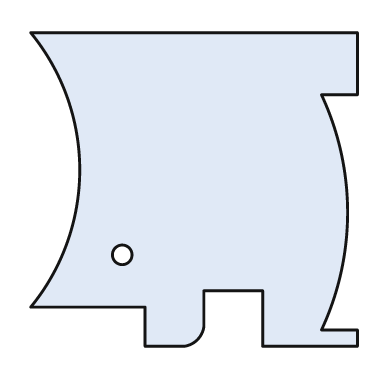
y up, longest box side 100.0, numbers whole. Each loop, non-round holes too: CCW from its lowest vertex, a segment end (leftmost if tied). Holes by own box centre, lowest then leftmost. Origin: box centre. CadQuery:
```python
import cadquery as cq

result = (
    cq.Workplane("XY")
    .moveTo(-15.0, -48.0)
    .lineTo(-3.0, -48.0)
    .threePointArc((1.0, -46.0), (3.0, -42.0))
    .lineTo(3.0, -31.0)
    .lineTo(21.0, -31.0)
    .lineTo(21.0, -48.0)
    .lineTo(50.0, -48.0)
    .lineTo(50.0, -43.0)
    .lineTo(39.0, -43.0)
    .threePointArc((47.0, -7.0), (39.0, 29.0))
    .lineTo(50.0, 29.0)
    .lineTo(50.0, 48.0)
    .lineTo(-50.0, 48.0)
    .threePointArc((-35.0, 6.0), (-50.0, -36.0))
    .lineTo(-15.0, -36.0)
    .close()
    .moveTo(-22.0, -20.0)
    .circle(3.0)
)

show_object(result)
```